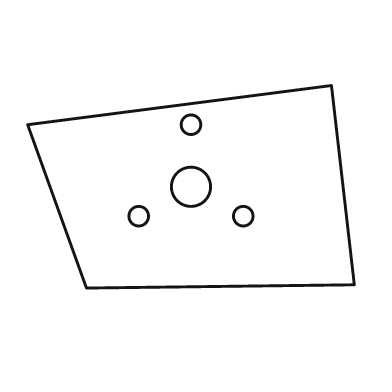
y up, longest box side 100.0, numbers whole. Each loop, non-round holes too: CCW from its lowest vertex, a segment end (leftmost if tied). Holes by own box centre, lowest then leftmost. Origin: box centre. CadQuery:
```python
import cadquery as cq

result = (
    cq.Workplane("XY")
    .moveTo(-32.0, -31.0)
    .lineTo(50.0, -30.0)
    .lineTo(43.0, 31.0)
    .lineTo(-50.0, 19.0)
    .close()
    .moveTo(-16.0, -9.0)
    .circle(3.0)
    .moveTo(16.0, -9.0)
    .circle(3.0)
    .moveTo(0.0, 0.0)
    .circle(6.0)
    .moveTo(0.0, 19.0)
    .circle(3.0)
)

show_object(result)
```